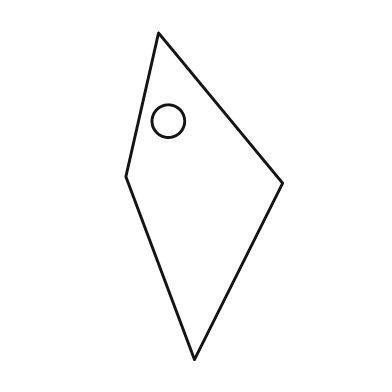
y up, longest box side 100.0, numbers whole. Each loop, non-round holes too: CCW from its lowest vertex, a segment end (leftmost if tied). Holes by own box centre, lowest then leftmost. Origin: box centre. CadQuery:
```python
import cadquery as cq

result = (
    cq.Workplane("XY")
    .moveTo(-3.0, -50.0)
    .lineTo(24.0, 4.0)
    .lineTo(-14.0, 50.0)
    .lineTo(-24.0, 6.0)
    .close()
    .moveTo(-11.0, 23.0)
    .circle(5.0)
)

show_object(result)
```